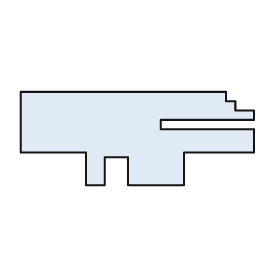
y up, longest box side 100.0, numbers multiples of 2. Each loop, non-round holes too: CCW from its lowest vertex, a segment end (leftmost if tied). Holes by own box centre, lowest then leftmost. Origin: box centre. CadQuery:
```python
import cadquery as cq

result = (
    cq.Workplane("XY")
    .moveTo(-22.0, -20.0)
    .lineTo(-14.0, -20.0)
    .lineTo(-14.0, -8.0)
    .lineTo(-4.0, -8.0)
    .lineTo(-4.0, -20.0)
    .lineTo(20.0, -20.0)
    .lineTo(20.0, -6.0)
    .lineTo(50.0, -6.0)
    .lineTo(50.0, 4.0)
    .lineTo(10.0, 4.0)
    .lineTo(10.0, 8.0)
    .lineTo(50.0, 8.0)
    .lineTo(50.0, 12.0)
    .lineTo(42.0, 12.0)
    .lineTo(42.0, 16.0)
    .lineTo(38.0, 16.0)
    .lineTo(38.0, 20.0)
    .lineTo(-50.0, 20.0)
    .lineTo(-50.0, -6.0)
    .lineTo(-22.0, -6.0)
    .close()
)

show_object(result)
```